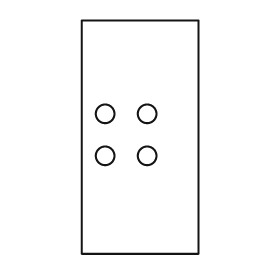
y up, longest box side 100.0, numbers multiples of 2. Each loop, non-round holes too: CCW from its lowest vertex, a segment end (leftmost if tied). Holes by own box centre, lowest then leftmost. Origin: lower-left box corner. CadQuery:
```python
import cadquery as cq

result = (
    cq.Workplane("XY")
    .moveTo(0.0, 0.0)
    .lineTo(50.0, 0.0)
    .lineTo(50.0, 100.0)
    .lineTo(0.0, 100.0)
    .close()
    .moveTo(10.0, 42.0)
    .circle(4.0)
    .moveTo(28.0, 42.0)
    .circle(4.0)
    .moveTo(10.0, 60.0)
    .circle(4.0)
    .moveTo(28.0, 60.0)
    .circle(4.0)
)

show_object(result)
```